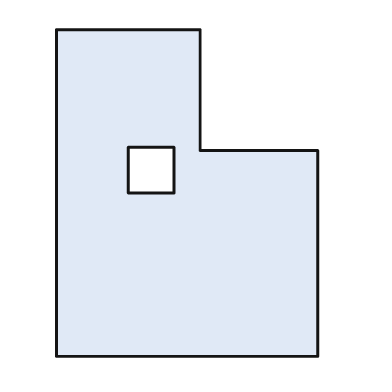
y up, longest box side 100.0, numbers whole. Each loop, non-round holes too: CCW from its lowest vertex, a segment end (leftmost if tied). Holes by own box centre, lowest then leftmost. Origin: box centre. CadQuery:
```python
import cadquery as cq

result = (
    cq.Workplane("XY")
    .moveTo(-40.0, -50.0)
    .lineTo(40.0, -50.0)
    .lineTo(40.0, 13.0)
    .lineTo(4.0, 13.0)
    .lineTo(4.0, 50.0)
    .lineTo(-40.0, 50.0)
    .close()
    .moveTo(-18.0, 0.0)
    .lineTo(-4.0, 0.0)
    .lineTo(-4.0, 14.0)
    .lineTo(-18.0, 14.0)
    .close()
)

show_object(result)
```